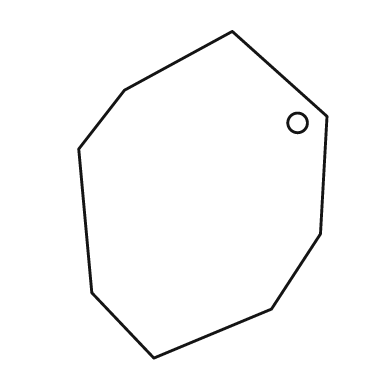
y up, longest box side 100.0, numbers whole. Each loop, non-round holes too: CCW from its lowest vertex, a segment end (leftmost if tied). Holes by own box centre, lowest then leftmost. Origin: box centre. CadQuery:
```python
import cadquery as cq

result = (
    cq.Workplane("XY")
    .moveTo(-15.0, -50.0)
    .lineTo(21.0, -35.0)
    .lineTo(36.0, -12.0)
    .lineTo(38.0, 24.0)
    .lineTo(9.0, 50.0)
    .lineTo(-24.0, 32.0)
    .lineTo(-38.0, 14.0)
    .lineTo(-34.0, -30.0)
    .close()
    .moveTo(29.0, 22.0)
    .circle(3.0)
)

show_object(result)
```